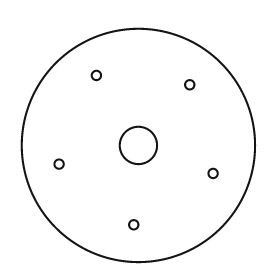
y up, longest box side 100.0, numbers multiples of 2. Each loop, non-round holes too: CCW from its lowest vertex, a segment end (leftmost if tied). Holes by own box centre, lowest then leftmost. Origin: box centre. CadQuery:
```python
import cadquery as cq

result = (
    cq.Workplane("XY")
    .moveTo(0.0, 0.0)
    .circle(50.0)
    .moveTo(-2.0, -34.0)
    .circle(2.0)
    .moveTo(32.0, -12.0)
    .circle(2.0)
    .moveTo(-34.0, -8.0)
    .circle(2.0)
    .moveTo(0.0, 0.0)
    .circle(8.0)
    .moveTo(22.0, 26.0)
    .circle(2.0)
    .moveTo(-18.0, 30.0)
    .circle(2.0)
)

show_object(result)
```